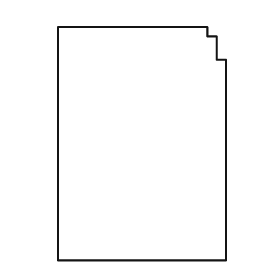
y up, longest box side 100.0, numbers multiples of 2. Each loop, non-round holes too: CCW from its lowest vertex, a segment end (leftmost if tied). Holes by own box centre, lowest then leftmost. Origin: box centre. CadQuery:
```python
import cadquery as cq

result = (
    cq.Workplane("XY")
    .moveTo(-36.0, -50.0)
    .lineTo(36.0, -50.0)
    .lineTo(36.0, 36.0)
    .lineTo(32.0, 36.0)
    .lineTo(32.0, 46.0)
    .lineTo(28.0, 46.0)
    .lineTo(28.0, 50.0)
    .lineTo(-36.0, 50.0)
    .close()
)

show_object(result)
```